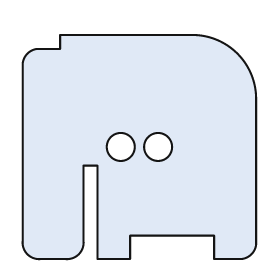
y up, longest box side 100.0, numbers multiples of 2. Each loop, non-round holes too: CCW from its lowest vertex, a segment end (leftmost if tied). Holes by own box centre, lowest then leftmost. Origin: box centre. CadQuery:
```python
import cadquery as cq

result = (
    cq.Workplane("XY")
    .moveTo(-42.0, -48.0)
    .lineTo(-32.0, -48.0)
    .threePointArc((-26.0, -46.0), (-24.0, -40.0))
    .lineTo(-24.0, -8.0)
    .lineTo(-18.0, -8.0)
    .lineTo(-18.0, -48.0)
    .lineTo(-4.0, -48.0)
    .lineTo(-4.0, -38.0)
    .lineTo(32.0, -38.0)
    .lineTo(32.0, -48.0)
    .lineTo(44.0, -48.0)
    .threePointArc((48.0, -46.0), (50.0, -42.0))
    .lineTo(50.0, 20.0)
    .threePointArc((42.0, 40.0), (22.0, 48.0))
    .lineTo(-34.0, 48.0)
    .lineTo(-34.0, 42.0)
    .lineTo(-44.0, 42.0)
    .threePointArc((-48.0, 40.0), (-50.0, 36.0))
    .lineTo(-50.0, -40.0)
    .threePointArc((-48.0, -46.0), (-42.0, -48.0))
    .close()
    .moveTo(-8.0, 0.0)
    .circle(6.0)
    .moveTo(8.0, 0.0)
    .circle(6.0)
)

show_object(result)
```